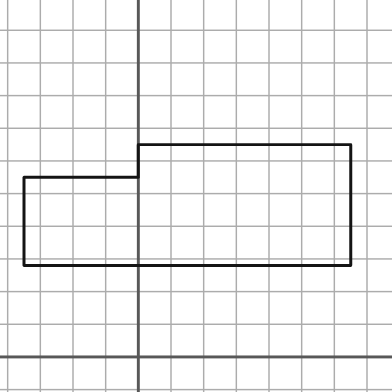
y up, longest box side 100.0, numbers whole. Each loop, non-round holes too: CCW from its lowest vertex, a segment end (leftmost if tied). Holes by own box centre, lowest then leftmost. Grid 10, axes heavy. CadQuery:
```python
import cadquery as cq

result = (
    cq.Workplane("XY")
    .moveTo(-35.0, 28.0)
    .lineTo(65.0, 28.0)
    .lineTo(65.0, 65.0)
    .lineTo(0.0, 65.0)
    .lineTo(0.0, 55.0)
    .lineTo(-35.0, 55.0)
    .close()
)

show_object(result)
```